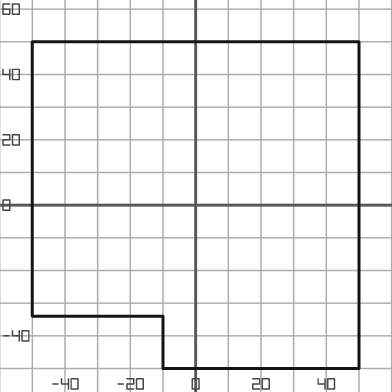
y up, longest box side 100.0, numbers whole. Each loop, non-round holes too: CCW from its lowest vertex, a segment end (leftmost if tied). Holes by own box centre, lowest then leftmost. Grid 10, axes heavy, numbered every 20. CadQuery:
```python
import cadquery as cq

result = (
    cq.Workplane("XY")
    .moveTo(-10.0, -50.0)
    .lineTo(50.0, -50.0)
    .lineTo(50.0, 50.0)
    .lineTo(-50.0, 50.0)
    .lineTo(-50.0, -34.0)
    .lineTo(-10.0, -34.0)
    .close()
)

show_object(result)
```